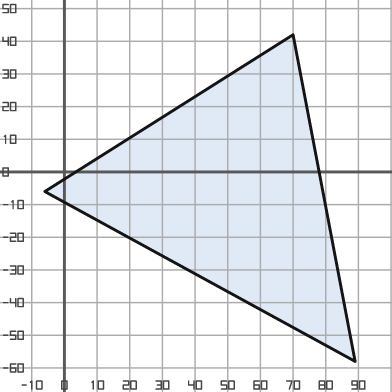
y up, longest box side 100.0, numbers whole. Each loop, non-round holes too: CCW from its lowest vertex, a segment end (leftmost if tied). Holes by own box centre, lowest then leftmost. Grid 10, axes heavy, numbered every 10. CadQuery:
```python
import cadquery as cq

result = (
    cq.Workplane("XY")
    .moveTo(89.0, -58.0)
    .lineTo(70.0, 42.0)
    .lineTo(-6.0, -6.0)
    .close()
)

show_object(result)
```